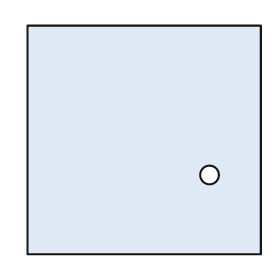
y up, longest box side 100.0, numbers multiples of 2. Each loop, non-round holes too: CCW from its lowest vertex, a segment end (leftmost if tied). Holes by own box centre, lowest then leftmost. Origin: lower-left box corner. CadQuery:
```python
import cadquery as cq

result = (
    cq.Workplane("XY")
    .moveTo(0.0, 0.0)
    .lineTo(100.0, 0.0)
    .lineTo(100.0, 98.0)
    .lineTo(0.0, 98.0)
    .close()
    .moveTo(78.0, 34.0)
    .circle(4.0)
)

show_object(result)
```